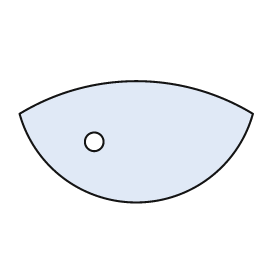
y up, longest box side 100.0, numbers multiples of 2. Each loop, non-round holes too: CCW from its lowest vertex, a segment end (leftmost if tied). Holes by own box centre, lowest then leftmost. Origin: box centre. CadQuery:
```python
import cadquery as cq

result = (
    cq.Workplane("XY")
    .moveTo(-50.0, 12.0)
    .threePointArc((0.0, -26.0), (50.0, 12.0))
    .threePointArc((0.0, 26.0), (-50.0, 12.0))
    .close()
    .moveTo(-18.0, 0.0)
    .circle(4.0)
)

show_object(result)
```